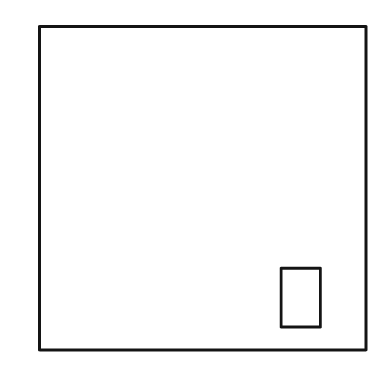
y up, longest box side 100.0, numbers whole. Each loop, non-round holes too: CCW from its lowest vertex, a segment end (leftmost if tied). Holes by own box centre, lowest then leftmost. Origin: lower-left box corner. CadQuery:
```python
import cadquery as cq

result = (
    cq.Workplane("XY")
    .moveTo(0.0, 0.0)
    .lineTo(100.0, 0.0)
    .lineTo(100.0, 99.0)
    .lineTo(0.0, 99.0)
    .close()
    .moveTo(74.0, 7.0)
    .lineTo(86.0, 7.0)
    .lineTo(86.0, 25.0)
    .lineTo(74.0, 25.0)
    .close()
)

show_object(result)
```